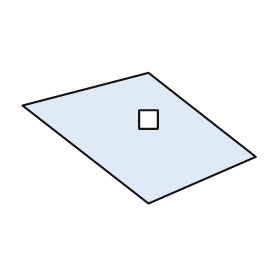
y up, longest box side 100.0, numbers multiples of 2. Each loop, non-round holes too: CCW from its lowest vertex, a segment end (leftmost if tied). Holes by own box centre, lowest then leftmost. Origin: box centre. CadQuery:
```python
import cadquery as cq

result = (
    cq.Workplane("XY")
    .moveTo(4.0, -28.0)
    .lineTo(50.0, -8.0)
    .lineTo(4.0, 28.0)
    .lineTo(-50.0, 14.0)
    .close()
    .moveTo(0.0, 4.0)
    .lineTo(8.0, 4.0)
    .lineTo(8.0, 12.0)
    .lineTo(0.0, 12.0)
    .close()
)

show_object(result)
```